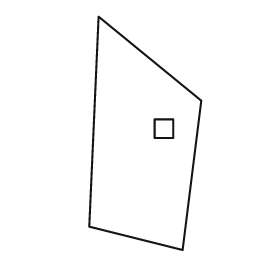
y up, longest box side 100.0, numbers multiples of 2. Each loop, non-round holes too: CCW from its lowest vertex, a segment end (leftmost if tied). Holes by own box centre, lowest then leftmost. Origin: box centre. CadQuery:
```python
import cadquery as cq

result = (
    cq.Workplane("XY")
    .moveTo(16.0, -50.0)
    .lineTo(24.0, 14.0)
    .lineTo(-20.0, 50.0)
    .lineTo(-24.0, -40.0)
    .close()
    .moveTo(4.0, -2.0)
    .lineTo(12.0, -2.0)
    .lineTo(12.0, 6.0)
    .lineTo(4.0, 6.0)
    .close()
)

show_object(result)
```